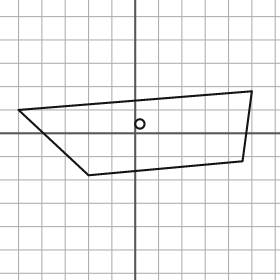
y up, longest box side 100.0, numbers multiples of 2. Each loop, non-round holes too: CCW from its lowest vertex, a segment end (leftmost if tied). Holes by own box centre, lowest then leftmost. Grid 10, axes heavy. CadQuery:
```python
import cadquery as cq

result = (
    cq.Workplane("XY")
    .moveTo(-20.0, -18.0)
    .lineTo(46.0, -12.0)
    .lineTo(50.0, 18.0)
    .lineTo(-50.0, 10.0)
    .close()
    .moveTo(2.0, 4.0)
    .circle(2.0)
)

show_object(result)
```